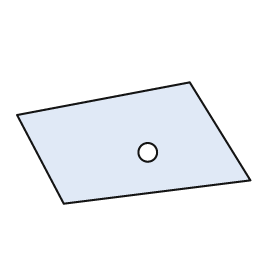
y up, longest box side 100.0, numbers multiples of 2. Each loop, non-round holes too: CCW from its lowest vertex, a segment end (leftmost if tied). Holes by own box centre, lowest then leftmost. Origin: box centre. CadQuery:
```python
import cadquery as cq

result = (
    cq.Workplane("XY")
    .moveTo(-30.0, -26.0)
    .lineTo(50.0, -16.0)
    .lineTo(24.0, 26.0)
    .lineTo(-50.0, 12.0)
    .close()
    .moveTo(6.0, -4.0)
    .circle(4.0)
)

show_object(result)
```